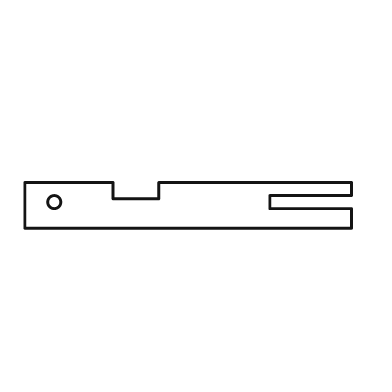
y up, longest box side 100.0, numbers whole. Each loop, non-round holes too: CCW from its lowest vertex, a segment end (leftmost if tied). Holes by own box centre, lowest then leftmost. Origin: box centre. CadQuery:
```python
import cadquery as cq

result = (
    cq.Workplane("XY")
    .moveTo(-50.0, -7.0)
    .lineTo(50.0, -7.0)
    .lineTo(50.0, -1.0)
    .lineTo(25.0, -1.0)
    .lineTo(25.0, 3.0)
    .lineTo(50.0, 3.0)
    .lineTo(50.0, 7.0)
    .lineTo(-9.0, 7.0)
    .lineTo(-9.0, 2.0)
    .lineTo(-23.0, 2.0)
    .lineTo(-23.0, 7.0)
    .lineTo(-50.0, 7.0)
    .close()
    .moveTo(-41.0, 1.0)
    .circle(2.0)
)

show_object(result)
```